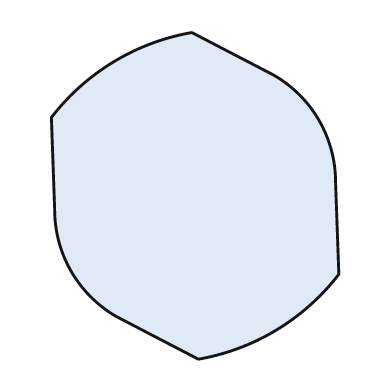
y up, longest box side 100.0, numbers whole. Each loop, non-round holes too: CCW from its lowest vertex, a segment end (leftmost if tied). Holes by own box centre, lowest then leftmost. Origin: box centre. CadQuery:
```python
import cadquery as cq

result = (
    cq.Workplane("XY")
    .moveTo(1.0, -50.0)
    .threePointArc((25.0, -41.0), (44.0, -24.0))
    .lineTo(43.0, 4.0)
    .threePointArc((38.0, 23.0), (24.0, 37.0))
    .lineTo(-1.0, 50.0)
    .threePointArc((-25.0, 41.0), (-44.0, 24.0))
    .lineTo(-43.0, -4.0)
    .threePointArc((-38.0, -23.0), (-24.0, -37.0))
    .close()
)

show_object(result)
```